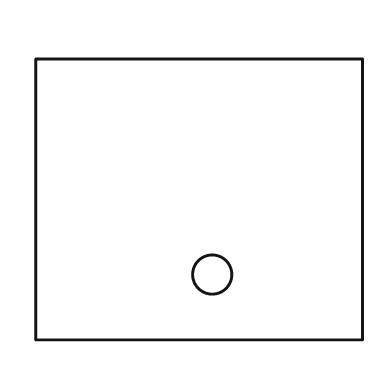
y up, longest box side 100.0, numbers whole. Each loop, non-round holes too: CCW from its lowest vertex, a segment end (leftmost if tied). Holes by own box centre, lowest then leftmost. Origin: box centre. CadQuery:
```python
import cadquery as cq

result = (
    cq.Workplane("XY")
    .moveTo(-50.0, -43.0)
    .lineTo(50.0, -43.0)
    .lineTo(50.0, 43.0)
    .lineTo(-50.0, 43.0)
    .close()
    .moveTo(4.0, -23.0)
    .circle(6.0)
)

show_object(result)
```